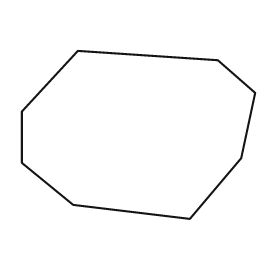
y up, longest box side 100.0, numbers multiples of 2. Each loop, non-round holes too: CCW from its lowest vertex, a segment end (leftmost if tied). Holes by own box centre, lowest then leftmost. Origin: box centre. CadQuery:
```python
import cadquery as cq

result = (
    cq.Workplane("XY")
    .moveTo(22.0, -36.0)
    .lineTo(44.0, -10.0)
    .lineTo(50.0, 18.0)
    .lineTo(34.0, 32.0)
    .lineTo(-26.0, 36.0)
    .lineTo(-50.0, 10.0)
    .lineTo(-50.0, -12.0)
    .lineTo(-28.0, -30.0)
    .close()
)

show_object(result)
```